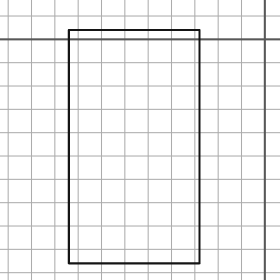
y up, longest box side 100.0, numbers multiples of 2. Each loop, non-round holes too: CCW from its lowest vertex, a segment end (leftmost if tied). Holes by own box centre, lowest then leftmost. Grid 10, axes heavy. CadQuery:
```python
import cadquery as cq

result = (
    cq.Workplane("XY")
    .moveTo(-84.0, -96.0)
    .lineTo(-28.0, -96.0)
    .lineTo(-28.0, 4.0)
    .lineTo(-84.0, 4.0)
    .close()
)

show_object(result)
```